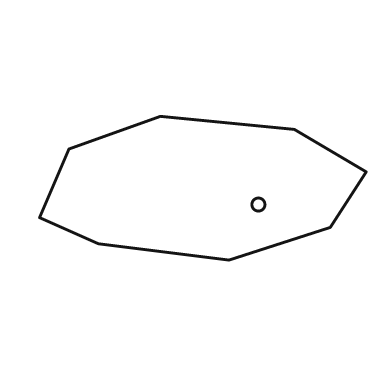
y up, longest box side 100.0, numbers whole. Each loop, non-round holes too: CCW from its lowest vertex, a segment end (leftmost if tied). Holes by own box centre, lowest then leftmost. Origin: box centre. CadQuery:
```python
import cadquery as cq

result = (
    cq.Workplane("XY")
    .moveTo(8.0, -22.0)
    .lineTo(39.0, -12.0)
    .lineTo(50.0, 5.0)
    .lineTo(28.0, 18.0)
    .lineTo(-13.0, 22.0)
    .lineTo(-41.0, 12.0)
    .lineTo(-50.0, -9.0)
    .lineTo(-32.0, -17.0)
    .close()
    .moveTo(17.0, -5.0)
    .circle(2.0)
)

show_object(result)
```